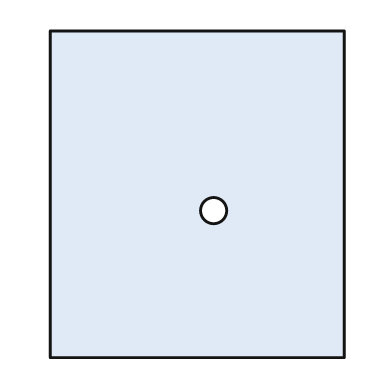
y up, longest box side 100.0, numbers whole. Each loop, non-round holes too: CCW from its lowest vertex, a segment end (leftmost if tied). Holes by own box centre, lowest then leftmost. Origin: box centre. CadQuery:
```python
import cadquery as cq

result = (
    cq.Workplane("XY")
    .moveTo(-45.0, -50.0)
    .lineTo(45.0, -50.0)
    .lineTo(45.0, 50.0)
    .lineTo(-45.0, 50.0)
    .close()
    .moveTo(5.0, -5.0)
    .circle(4.0)
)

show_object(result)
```